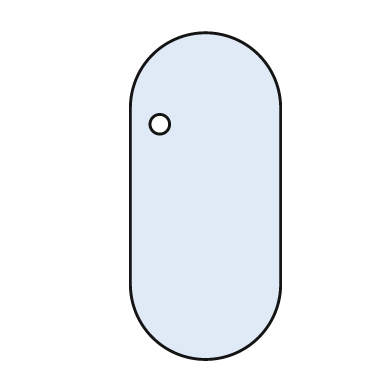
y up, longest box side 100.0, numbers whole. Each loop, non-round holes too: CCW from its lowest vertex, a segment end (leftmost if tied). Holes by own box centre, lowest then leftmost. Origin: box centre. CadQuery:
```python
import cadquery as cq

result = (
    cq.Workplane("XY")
    .moveTo(-23.0, -27.0)
    .threePointArc((0.0, -50.0), (23.0, -27.0))
    .lineTo(23.0, 27.0)
    .threePointArc((0.0, 50.0), (-23.0, 27.0))
    .close()
    .moveTo(-14.0, 22.0)
    .circle(3.0)
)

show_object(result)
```